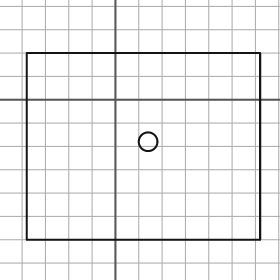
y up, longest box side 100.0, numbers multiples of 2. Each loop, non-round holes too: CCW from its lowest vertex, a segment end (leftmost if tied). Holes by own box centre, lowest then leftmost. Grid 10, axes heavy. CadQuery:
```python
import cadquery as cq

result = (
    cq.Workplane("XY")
    .moveTo(-38.0, -60.0)
    .lineTo(62.0, -60.0)
    .lineTo(62.0, 20.0)
    .lineTo(-38.0, 20.0)
    .close()
    .moveTo(14.0, -18.0)
    .circle(4.0)
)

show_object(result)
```